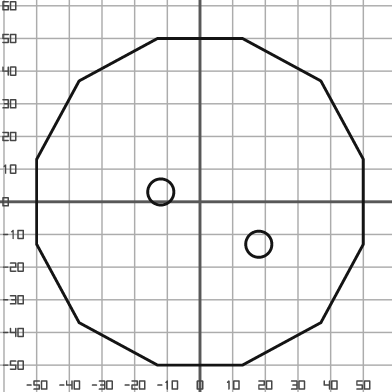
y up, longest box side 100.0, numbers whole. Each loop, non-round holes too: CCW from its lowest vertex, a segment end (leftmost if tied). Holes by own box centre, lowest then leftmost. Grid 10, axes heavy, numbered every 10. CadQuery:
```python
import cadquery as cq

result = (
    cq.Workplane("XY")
    .moveTo(-13.0, -50.0)
    .lineTo(13.0, -50.0)
    .lineTo(37.0, -37.0)
    .lineTo(50.0, -13.0)
    .lineTo(50.0, 13.0)
    .lineTo(37.0, 37.0)
    .lineTo(13.0, 50.0)
    .lineTo(-13.0, 50.0)
    .lineTo(-37.0, 37.0)
    .lineTo(-50.0, 13.0)
    .lineTo(-50.0, -13.0)
    .lineTo(-37.0, -37.0)
    .close()
    .moveTo(18.0, -13.0)
    .circle(4.0)
    .moveTo(-12.0, 3.0)
    .circle(4.0)
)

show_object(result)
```